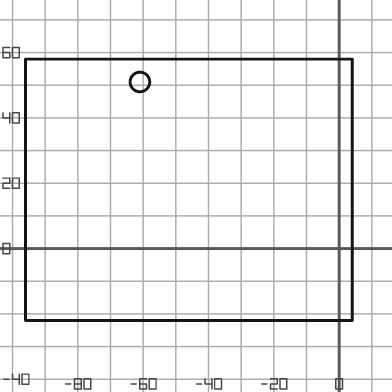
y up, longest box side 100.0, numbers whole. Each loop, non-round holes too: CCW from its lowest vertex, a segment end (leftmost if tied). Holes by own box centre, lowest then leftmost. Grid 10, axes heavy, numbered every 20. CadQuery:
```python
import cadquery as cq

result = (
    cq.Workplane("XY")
    .moveTo(-96.0, -22.0)
    .lineTo(4.0, -22.0)
    .lineTo(4.0, 58.0)
    .lineTo(-96.0, 58.0)
    .close()
    .moveTo(-61.0, 51.0)
    .circle(3.0)
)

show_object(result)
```